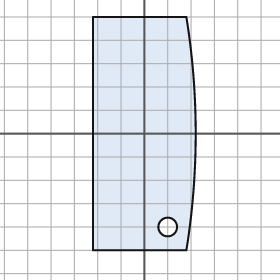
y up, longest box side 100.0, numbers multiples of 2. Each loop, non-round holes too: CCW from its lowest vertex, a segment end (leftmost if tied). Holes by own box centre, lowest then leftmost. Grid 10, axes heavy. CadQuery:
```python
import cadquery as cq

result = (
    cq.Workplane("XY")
    .moveTo(-22.0, -50.0)
    .lineTo(18.0, -50.0)
    .threePointArc((22.0, 0.0), (18.0, 50.0))
    .lineTo(-22.0, 50.0)
    .close()
    .moveTo(10.0, -40.0)
    .circle(4.0)
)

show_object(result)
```